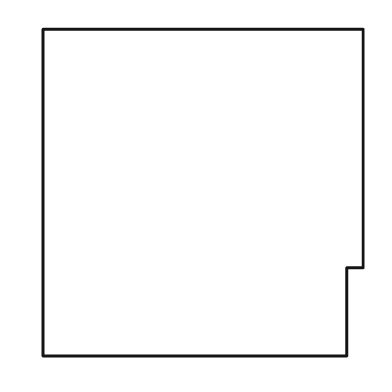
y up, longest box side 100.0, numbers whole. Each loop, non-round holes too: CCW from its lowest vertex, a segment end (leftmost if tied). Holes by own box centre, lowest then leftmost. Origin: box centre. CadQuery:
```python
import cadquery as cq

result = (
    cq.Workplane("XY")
    .moveTo(-49.0, -50.0)
    .lineTo(44.0, -50.0)
    .lineTo(44.0, -23.0)
    .lineTo(49.0, -23.0)
    .lineTo(49.0, 50.0)
    .lineTo(-49.0, 50.0)
    .close()
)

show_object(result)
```